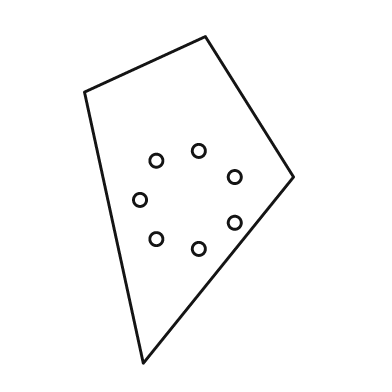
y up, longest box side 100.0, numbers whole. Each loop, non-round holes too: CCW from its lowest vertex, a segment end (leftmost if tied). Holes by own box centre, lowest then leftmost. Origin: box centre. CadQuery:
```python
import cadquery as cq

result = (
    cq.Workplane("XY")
    .moveTo(-14.0, -50.0)
    .lineTo(32.0, 7.0)
    .lineTo(5.0, 50.0)
    .lineTo(-32.0, 33.0)
    .close()
    .moveTo(3.0, -15.0)
    .circle(2.0)
    .moveTo(-10.0, -12.0)
    .circle(2.0)
    .moveTo(14.0, -7.0)
    .circle(2.0)
    .moveTo(-15.0, 0.0)
    .circle(2.0)
    .moveTo(14.0, 7.0)
    .circle(2.0)
    .moveTo(-10.0, 12.0)
    .circle(2.0)
    .moveTo(3.0, 15.0)
    .circle(2.0)
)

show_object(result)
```